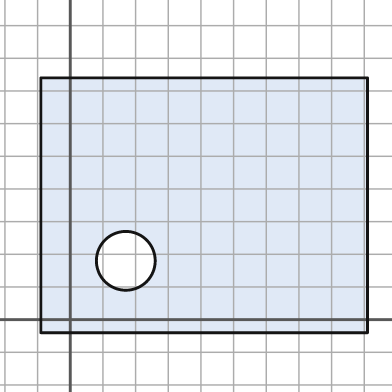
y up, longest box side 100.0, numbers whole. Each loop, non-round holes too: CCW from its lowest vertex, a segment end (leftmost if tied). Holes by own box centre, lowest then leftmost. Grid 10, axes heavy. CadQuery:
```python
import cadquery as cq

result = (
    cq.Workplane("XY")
    .moveTo(-9.0, -4.0)
    .lineTo(91.0, -4.0)
    .lineTo(91.0, 74.0)
    .lineTo(-9.0, 74.0)
    .close()
    .moveTo(17.0, 18.0)
    .circle(9.0)
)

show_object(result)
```